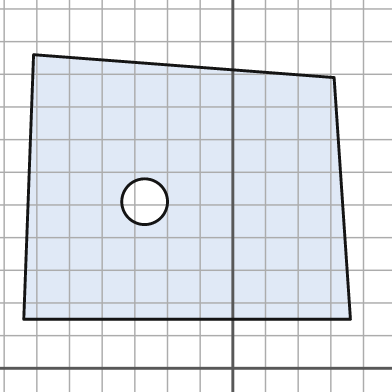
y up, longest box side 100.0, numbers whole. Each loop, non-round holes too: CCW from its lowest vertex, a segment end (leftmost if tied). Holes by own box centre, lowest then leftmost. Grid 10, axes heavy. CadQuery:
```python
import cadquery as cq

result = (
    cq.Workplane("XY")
    .moveTo(-64.0, 15.0)
    .lineTo(36.0, 15.0)
    .lineTo(31.0, 89.0)
    .lineTo(-61.0, 96.0)
    .close()
    .moveTo(-27.0, 51.0)
    .circle(7.0)
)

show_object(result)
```